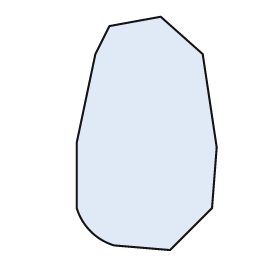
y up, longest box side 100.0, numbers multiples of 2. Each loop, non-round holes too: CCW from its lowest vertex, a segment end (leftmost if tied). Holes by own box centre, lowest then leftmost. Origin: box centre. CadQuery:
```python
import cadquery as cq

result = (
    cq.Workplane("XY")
    .moveTo(10.0, -50.0)
    .lineTo(28.0, -32.0)
    .lineTo(30.0, -6.0)
    .lineTo(24.0, 34.0)
    .lineTo(6.0, 50.0)
    .lineTo(-16.0, 46.0)
    .lineTo(-22.0, 34.0)
    .lineTo(-30.0, -4.0)
    .lineTo(-30.0, -32.0)
    .threePointArc((-24.0, -42.0), (-14.0, -48.0))
    .close()
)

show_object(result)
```